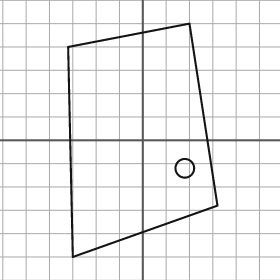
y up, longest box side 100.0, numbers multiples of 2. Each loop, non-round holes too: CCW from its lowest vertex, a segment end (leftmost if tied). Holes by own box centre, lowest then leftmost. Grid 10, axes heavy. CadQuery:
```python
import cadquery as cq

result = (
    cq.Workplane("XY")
    .moveTo(-30.0, -50.0)
    .lineTo(32.0, -28.0)
    .lineTo(20.0, 50.0)
    .lineTo(-32.0, 40.0)
    .close()
    .moveTo(18.0, -12.0)
    .circle(4.0)
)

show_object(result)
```